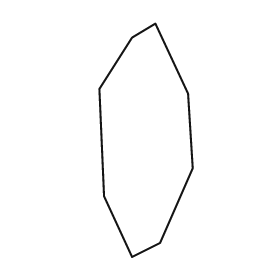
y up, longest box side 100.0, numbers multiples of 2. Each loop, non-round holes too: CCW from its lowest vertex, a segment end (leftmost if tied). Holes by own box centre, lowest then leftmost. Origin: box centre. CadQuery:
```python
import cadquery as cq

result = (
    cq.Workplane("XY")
    .moveTo(-6.0, -50.0)
    .lineTo(6.0, -44.0)
    .lineTo(20.0, -12.0)
    .lineTo(18.0, 20.0)
    .lineTo(4.0, 50.0)
    .lineTo(-6.0, 44.0)
    .lineTo(-20.0, 22.0)
    .lineTo(-18.0, -24.0)
    .close()
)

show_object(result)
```